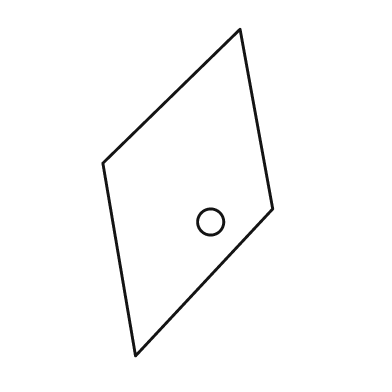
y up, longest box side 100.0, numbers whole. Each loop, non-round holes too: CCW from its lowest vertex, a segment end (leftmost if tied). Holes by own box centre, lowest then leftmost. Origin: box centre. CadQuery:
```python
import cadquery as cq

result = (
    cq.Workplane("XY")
    .moveTo(-16.0, -50.0)
    .lineTo(26.0, -5.0)
    .lineTo(16.0, 50.0)
    .lineTo(-26.0, 9.0)
    .close()
    .moveTo(7.0, -9.0)
    .circle(4.0)
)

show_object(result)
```